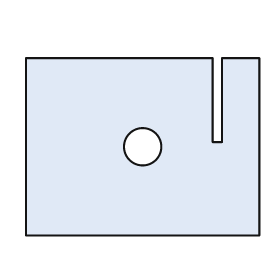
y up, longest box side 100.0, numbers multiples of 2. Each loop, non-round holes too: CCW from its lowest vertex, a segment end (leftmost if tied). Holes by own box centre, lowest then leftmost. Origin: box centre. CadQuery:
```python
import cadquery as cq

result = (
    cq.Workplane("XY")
    .moveTo(-50.0, -38.0)
    .lineTo(50.0, -38.0)
    .lineTo(50.0, 38.0)
    .lineTo(34.0, 38.0)
    .lineTo(34.0, 2.0)
    .lineTo(30.0, 2.0)
    .lineTo(30.0, 38.0)
    .lineTo(-50.0, 38.0)
    .close()
    .moveTo(0.0, 0.0)
    .circle(8.0)
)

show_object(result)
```